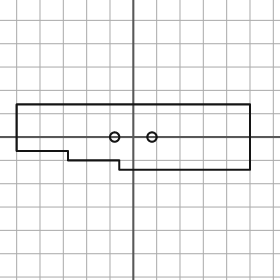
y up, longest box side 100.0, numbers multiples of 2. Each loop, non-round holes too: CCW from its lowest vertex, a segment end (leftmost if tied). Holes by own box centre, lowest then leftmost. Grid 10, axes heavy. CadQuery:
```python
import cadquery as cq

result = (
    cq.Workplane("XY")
    .moveTo(-6.0, -14.0)
    .lineTo(50.0, -14.0)
    .lineTo(50.0, 14.0)
    .lineTo(-50.0, 14.0)
    .lineTo(-50.0, -6.0)
    .lineTo(-28.0, -6.0)
    .lineTo(-28.0, -10.0)
    .lineTo(-6.0, -10.0)
    .close()
    .moveTo(-8.0, 0.0)
    .circle(2.0)
    .moveTo(8.0, 0.0)
    .circle(2.0)
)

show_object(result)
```